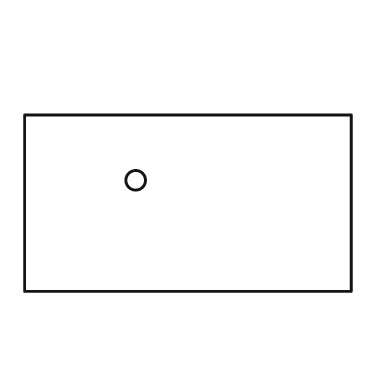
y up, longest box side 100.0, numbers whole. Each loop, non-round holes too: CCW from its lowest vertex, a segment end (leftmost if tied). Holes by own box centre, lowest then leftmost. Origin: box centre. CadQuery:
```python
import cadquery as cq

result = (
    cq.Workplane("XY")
    .moveTo(-50.0, -27.0)
    .lineTo(50.0, -27.0)
    .lineTo(50.0, 27.0)
    .lineTo(-50.0, 27.0)
    .close()
    .moveTo(-16.0, 7.0)
    .circle(3.0)
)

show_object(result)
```